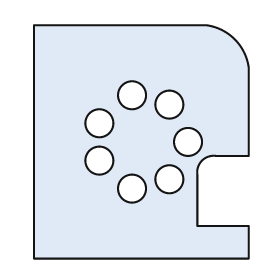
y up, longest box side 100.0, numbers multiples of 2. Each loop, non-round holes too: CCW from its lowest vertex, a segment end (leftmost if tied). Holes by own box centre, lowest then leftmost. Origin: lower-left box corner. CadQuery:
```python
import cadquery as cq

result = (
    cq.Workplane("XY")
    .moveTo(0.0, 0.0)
    .lineTo(92.0, 0.0)
    .lineTo(92.0, 14.0)
    .lineTo(70.0, 14.0)
    .lineTo(70.0, 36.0)
    .threePointArc((72.0, 42.0), (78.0, 44.0))
    .lineTo(92.0, 44.0)
    .lineTo(92.0, 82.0)
    .threePointArc((86.0, 94.0), (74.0, 100.0))
    .lineTo(0.0, 100.0)
    .close()
    .moveTo(42.0, 30.0)
    .circle(6.0)
    .moveTo(58.0, 34.0)
    .circle(6.0)
    .moveTo(28.0, 42.0)
    .circle(6.0)
    .moveTo(66.0, 50.0)
    .circle(6.0)
    .moveTo(28.0, 58.0)
    .circle(6.0)
    .moveTo(58.0, 66.0)
    .circle(6.0)
    .moveTo(42.0, 70.0)
    .circle(6.0)
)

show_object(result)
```